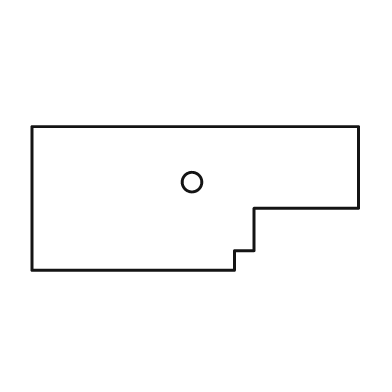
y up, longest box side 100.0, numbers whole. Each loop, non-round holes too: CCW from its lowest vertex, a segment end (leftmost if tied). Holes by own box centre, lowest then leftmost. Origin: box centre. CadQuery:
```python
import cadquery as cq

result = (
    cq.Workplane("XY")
    .moveTo(-50.0, -22.0)
    .lineTo(12.0, -22.0)
    .lineTo(12.0, -16.0)
    .lineTo(18.0, -16.0)
    .lineTo(18.0, -3.0)
    .lineTo(50.0, -3.0)
    .lineTo(50.0, 22.0)
    .lineTo(-50.0, 22.0)
    .close()
    .moveTo(-1.0, 5.0)
    .circle(3.0)
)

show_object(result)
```